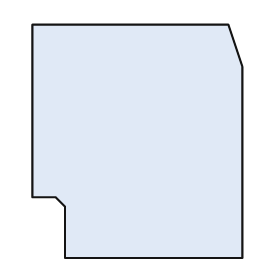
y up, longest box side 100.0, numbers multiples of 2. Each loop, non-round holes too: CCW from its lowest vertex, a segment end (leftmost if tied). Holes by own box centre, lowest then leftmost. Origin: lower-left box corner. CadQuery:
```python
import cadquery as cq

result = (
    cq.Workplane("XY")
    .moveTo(14.0, 0.0)
    .lineTo(90.0, 0.0)
    .lineTo(90.0, 82.0)
    .lineTo(84.0, 100.0)
    .lineTo(0.0, 100.0)
    .lineTo(0.0, 26.0)
    .lineTo(10.0, 26.0)
    .lineTo(14.0, 22.0)
    .close()
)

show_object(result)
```